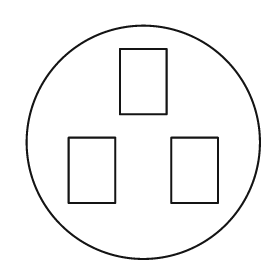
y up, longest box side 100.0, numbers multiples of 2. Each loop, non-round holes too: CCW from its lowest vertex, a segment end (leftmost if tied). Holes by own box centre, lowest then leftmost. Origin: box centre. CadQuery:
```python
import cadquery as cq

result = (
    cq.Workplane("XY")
    .moveTo(0.0, 0.0)
    .circle(50.0)
    .moveTo(-32.0, -26.0)
    .lineTo(-12.0, -26.0)
    .lineTo(-12.0, 2.0)
    .lineTo(-32.0, 2.0)
    .close()
    .moveTo(12.0, -26.0)
    .lineTo(32.0, -26.0)
    .lineTo(32.0, 2.0)
    .lineTo(12.0, 2.0)
    .close()
    .moveTo(-10.0, 12.0)
    .lineTo(10.0, 12.0)
    .lineTo(10.0, 40.0)
    .lineTo(-10.0, 40.0)
    .close()
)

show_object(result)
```